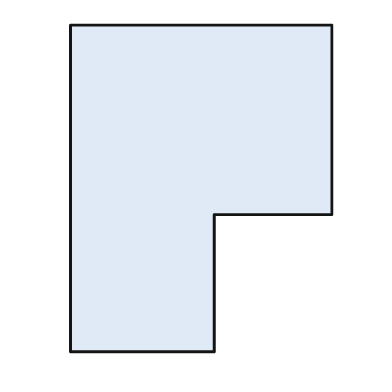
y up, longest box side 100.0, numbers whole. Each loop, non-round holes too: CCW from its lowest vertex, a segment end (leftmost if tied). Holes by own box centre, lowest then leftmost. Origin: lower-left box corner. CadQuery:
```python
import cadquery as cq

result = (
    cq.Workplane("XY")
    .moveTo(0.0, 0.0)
    .lineTo(44.0, 0.0)
    .lineTo(44.0, 42.0)
    .lineTo(80.0, 42.0)
    .lineTo(80.0, 100.0)
    .lineTo(0.0, 100.0)
    .close()
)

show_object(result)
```